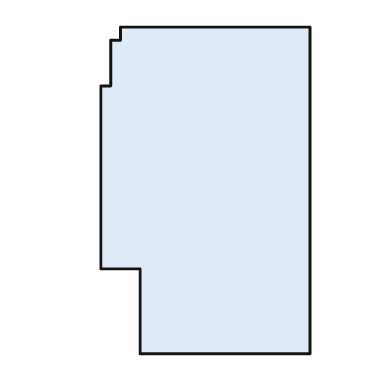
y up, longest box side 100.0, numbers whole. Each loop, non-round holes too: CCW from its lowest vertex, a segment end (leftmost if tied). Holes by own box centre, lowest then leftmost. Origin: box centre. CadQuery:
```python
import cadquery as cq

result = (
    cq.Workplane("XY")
    .moveTo(-20.0, -50.0)
    .lineTo(32.0, -50.0)
    .lineTo(32.0, 50.0)
    .lineTo(-26.0, 50.0)
    .lineTo(-26.0, 46.0)
    .lineTo(-29.0, 46.0)
    .lineTo(-29.0, 32.0)
    .lineTo(-32.0, 32.0)
    .lineTo(-32.0, -24.0)
    .lineTo(-20.0, -24.0)
    .close()
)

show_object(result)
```